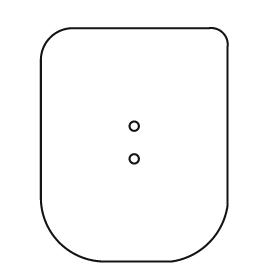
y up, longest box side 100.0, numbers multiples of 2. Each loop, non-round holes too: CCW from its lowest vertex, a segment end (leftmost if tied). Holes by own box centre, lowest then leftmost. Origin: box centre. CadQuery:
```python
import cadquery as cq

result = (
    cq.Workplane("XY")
    .moveTo(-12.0, -50.0)
    .lineTo(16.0, -50.0)
    .threePointArc((32.0, -42.0), (40.0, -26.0))
    .lineTo(40.0, 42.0)
    .threePointArc((38.0, 48.0), (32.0, 50.0))
    .lineTo(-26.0, 50.0)
    .threePointArc((-36.0, 46.0), (-40.0, 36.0))
    .lineTo(-40.0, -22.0)
    .threePointArc((-32.0, -42.0), (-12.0, -50.0))
    .close()
    .moveTo(0.0, -6.0)
    .circle(2.0)
    .moveTo(0.0, 8.0)
    .circle(2.0)
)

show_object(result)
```